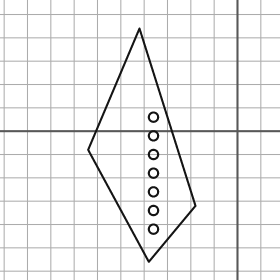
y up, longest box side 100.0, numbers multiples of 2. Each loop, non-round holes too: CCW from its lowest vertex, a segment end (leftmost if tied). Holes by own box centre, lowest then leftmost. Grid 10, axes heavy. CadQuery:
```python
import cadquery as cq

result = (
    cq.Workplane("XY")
    .moveTo(-38.0, -56.0)
    .lineTo(-18.0, -32.0)
    .lineTo(-42.0, 44.0)
    .lineTo(-64.0, -8.0)
    .close()
    .moveTo(-36.0, -42.0)
    .circle(2.0)
    .moveTo(-36.0, -34.0)
    .circle(2.0)
    .moveTo(-36.0, -26.0)
    .circle(2.0)
    .moveTo(-36.0, -18.0)
    .circle(2.0)
    .moveTo(-36.0, -10.0)
    .circle(2.0)
    .moveTo(-36.0, -2.0)
    .circle(2.0)
    .moveTo(-36.0, 6.0)
    .circle(2.0)
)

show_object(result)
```